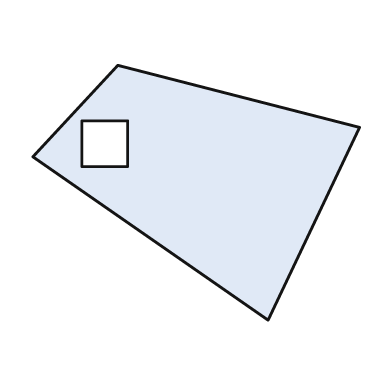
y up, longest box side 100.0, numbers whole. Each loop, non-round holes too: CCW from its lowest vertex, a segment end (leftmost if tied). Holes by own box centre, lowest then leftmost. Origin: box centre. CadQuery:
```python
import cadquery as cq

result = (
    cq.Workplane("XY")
    .moveTo(22.0, -39.0)
    .lineTo(50.0, 20.0)
    .lineTo(-24.0, 39.0)
    .lineTo(-50.0, 11.0)
    .close()
    .moveTo(-35.0, 8.0)
    .lineTo(-21.0, 8.0)
    .lineTo(-21.0, 22.0)
    .lineTo(-35.0, 22.0)
    .close()
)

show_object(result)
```